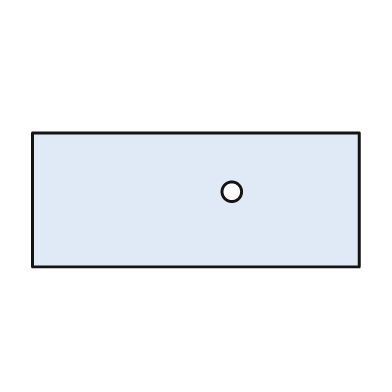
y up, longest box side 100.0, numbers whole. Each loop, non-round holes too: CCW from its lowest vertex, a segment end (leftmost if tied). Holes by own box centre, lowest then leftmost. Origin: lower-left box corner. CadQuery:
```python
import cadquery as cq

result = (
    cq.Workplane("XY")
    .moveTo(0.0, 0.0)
    .lineTo(100.0, 0.0)
    .lineTo(100.0, 41.0)
    .lineTo(0.0, 41.0)
    .close()
    .moveTo(61.0, 23.0)
    .circle(3.0)
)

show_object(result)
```